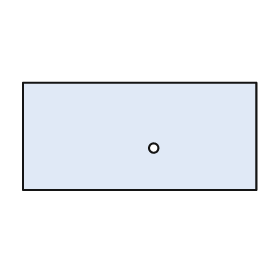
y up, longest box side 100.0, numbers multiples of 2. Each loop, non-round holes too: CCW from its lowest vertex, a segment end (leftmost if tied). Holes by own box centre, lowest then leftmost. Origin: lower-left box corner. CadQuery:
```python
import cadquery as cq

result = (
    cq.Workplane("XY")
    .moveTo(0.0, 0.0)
    .lineTo(100.0, 0.0)
    .lineTo(100.0, 46.0)
    .lineTo(0.0, 46.0)
    .close()
    .moveTo(56.0, 18.0)
    .circle(2.0)
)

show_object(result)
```